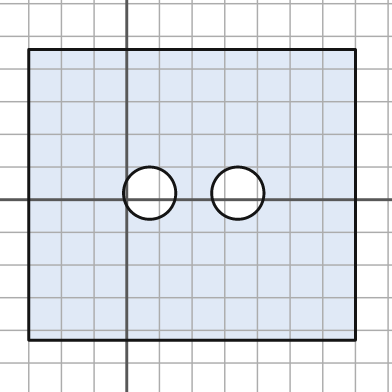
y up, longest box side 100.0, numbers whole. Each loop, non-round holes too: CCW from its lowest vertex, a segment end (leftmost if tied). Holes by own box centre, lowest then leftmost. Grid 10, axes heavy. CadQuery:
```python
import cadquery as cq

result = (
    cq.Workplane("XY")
    .moveTo(-30.0, -43.0)
    .lineTo(70.0, -43.0)
    .lineTo(70.0, 46.0)
    .lineTo(-30.0, 46.0)
    .close()
    .moveTo(7.0, 2.0)
    .circle(8.0)
    .moveTo(34.0, 2.0)
    .circle(8.0)
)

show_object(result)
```